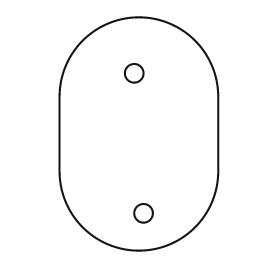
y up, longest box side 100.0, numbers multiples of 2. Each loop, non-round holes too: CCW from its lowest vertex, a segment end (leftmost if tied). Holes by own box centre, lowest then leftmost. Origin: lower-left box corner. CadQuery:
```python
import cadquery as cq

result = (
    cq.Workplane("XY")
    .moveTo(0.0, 34.0)
    .threePointArc((34.0, 0.0), (68.0, 34.0))
    .lineTo(68.0, 66.0)
    .threePointArc((34.0, 100.0), (0.0, 66.0))
    .close()
    .moveTo(36.0, 16.0)
    .circle(4.0)
    .moveTo(32.0, 76.0)
    .circle(4.0)
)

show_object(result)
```